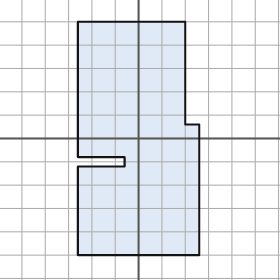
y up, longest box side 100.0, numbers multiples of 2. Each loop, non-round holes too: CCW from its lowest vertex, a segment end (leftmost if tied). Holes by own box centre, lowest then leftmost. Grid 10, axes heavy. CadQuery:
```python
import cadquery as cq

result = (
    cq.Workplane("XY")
    .moveTo(-26.0, -50.0)
    .lineTo(26.0, -50.0)
    .lineTo(26.0, 6.0)
    .lineTo(20.0, 6.0)
    .lineTo(20.0, 50.0)
    .lineTo(-26.0, 50.0)
    .lineTo(-26.0, -8.0)
    .lineTo(-6.0, -8.0)
    .lineTo(-6.0, -12.0)
    .lineTo(-26.0, -12.0)
    .close()
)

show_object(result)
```